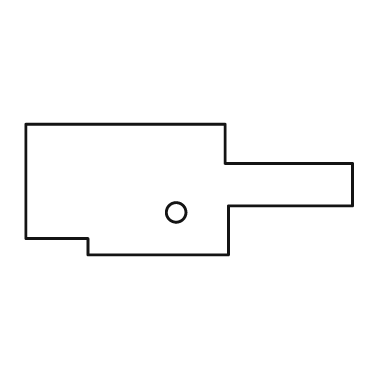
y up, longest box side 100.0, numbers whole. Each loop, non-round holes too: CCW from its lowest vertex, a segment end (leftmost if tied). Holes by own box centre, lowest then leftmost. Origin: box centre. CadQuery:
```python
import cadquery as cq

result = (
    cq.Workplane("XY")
    .moveTo(-31.0, -20.0)
    .lineTo(12.0, -20.0)
    .lineTo(12.0, -5.0)
    .lineTo(50.0, -5.0)
    .lineTo(50.0, 8.0)
    .lineTo(11.0, 8.0)
    .lineTo(11.0, 20.0)
    .lineTo(-50.0, 20.0)
    .lineTo(-50.0, -15.0)
    .lineTo(-31.0, -15.0)
    .close()
    .moveTo(-4.0, -7.0)
    .circle(3.0)
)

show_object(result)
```